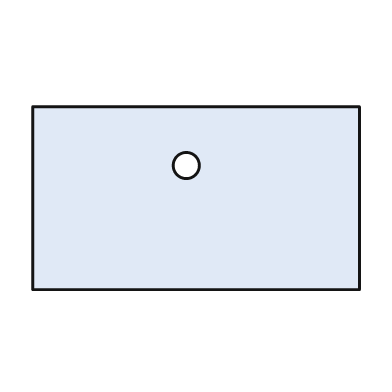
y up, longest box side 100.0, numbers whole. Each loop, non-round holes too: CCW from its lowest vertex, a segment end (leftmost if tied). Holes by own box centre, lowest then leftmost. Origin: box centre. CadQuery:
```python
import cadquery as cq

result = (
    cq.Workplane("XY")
    .moveTo(-50.0, -28.0)
    .lineTo(50.0, -28.0)
    .lineTo(50.0, 28.0)
    .lineTo(-50.0, 28.0)
    .close()
    .moveTo(-3.0, 10.0)
    .circle(4.0)
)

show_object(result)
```